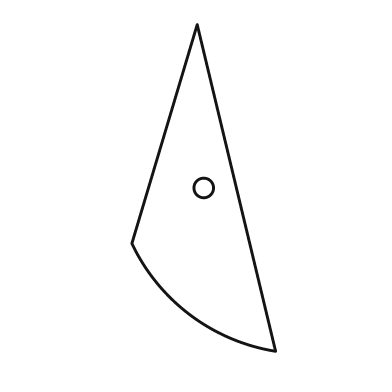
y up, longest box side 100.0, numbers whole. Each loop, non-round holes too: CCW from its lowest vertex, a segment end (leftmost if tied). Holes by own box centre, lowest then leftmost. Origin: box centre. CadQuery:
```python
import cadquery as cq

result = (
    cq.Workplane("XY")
    .moveTo(22.0, -50.0)
    .lineTo(-2.0, 50.0)
    .lineTo(-22.0, -17.0)
    .threePointArc((-4.0, -39.0), (22.0, -50.0))
    .close()
    .moveTo(0.0, 0.0)
    .circle(3.0)
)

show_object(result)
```